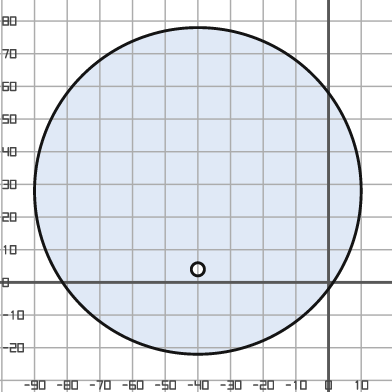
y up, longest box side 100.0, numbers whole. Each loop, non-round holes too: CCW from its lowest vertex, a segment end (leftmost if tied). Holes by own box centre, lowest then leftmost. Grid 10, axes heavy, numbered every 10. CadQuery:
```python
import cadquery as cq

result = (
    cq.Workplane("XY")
    .moveTo(-40.0, 28.0)
    .circle(50.0)
    .moveTo(-40.0, 4.0)
    .circle(2.0)
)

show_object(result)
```